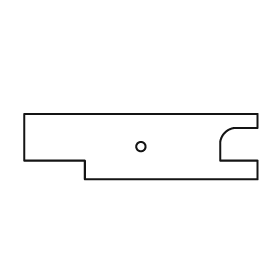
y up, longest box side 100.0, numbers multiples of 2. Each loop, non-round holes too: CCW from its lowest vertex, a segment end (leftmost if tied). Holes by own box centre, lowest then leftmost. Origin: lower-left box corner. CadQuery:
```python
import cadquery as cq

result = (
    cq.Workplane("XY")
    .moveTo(26.0, 0.0)
    .lineTo(100.0, 0.0)
    .lineTo(100.0, 8.0)
    .lineTo(84.0, 8.0)
    .lineTo(84.0, 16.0)
    .threePointArc((86.0, 20.0), (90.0, 22.0))
    .lineTo(100.0, 22.0)
    .lineTo(100.0, 28.0)
    .lineTo(0.0, 28.0)
    .lineTo(0.0, 8.0)
    .lineTo(26.0, 8.0)
    .close()
    .moveTo(50.0, 14.0)
    .circle(2.0)
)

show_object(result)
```